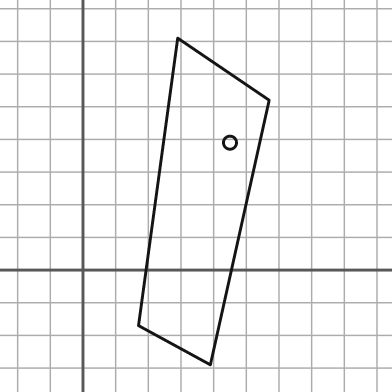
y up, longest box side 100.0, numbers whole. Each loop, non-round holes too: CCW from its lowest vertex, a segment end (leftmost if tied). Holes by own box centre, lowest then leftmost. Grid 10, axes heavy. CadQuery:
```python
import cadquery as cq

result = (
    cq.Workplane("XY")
    .moveTo(39.0, -29.0)
    .lineTo(57.0, 52.0)
    .lineTo(29.0, 71.0)
    .lineTo(17.0, -17.0)
    .close()
    .moveTo(45.0, 39.0)
    .circle(2.0)
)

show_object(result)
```